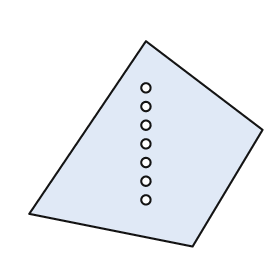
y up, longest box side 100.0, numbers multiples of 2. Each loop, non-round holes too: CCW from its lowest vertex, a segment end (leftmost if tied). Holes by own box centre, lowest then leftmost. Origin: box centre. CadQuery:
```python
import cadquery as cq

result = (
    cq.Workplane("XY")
    .moveTo(20.0, -44.0)
    .lineTo(50.0, 6.0)
    .lineTo(0.0, 44.0)
    .lineTo(-50.0, -30.0)
    .close()
    .moveTo(0.0, -24.0)
    .circle(2.0)
    .moveTo(0.0, -16.0)
    .circle(2.0)
    .moveTo(0.0, -8.0)
    .circle(2.0)
    .moveTo(0.0, 0.0)
    .circle(2.0)
    .moveTo(0.0, 8.0)
    .circle(2.0)
    .moveTo(0.0, 16.0)
    .circle(2.0)
    .moveTo(0.0, 24.0)
    .circle(2.0)
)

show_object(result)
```